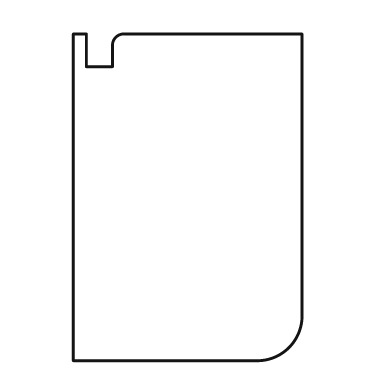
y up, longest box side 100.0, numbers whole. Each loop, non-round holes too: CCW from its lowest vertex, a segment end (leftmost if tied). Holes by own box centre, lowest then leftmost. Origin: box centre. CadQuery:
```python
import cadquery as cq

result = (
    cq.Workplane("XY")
    .moveTo(-35.0, -50.0)
    .lineTo(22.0, -50.0)
    .threePointArc((31.0, -46.0), (35.0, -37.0))
    .lineTo(35.0, 50.0)
    .lineTo(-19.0, 50.0)
    .threePointArc((-22.0, 49.0), (-23.0, 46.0))
    .lineTo(-23.0, 40.0)
    .lineTo(-31.0, 40.0)
    .lineTo(-31.0, 50.0)
    .lineTo(-35.0, 50.0)
    .close()
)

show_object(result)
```